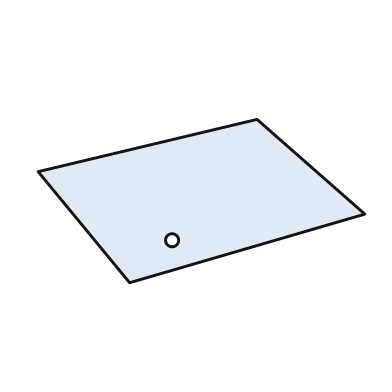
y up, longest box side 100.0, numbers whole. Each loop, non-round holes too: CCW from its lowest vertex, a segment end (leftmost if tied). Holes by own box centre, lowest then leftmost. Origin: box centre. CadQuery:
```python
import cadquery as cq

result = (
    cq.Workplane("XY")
    .moveTo(-22.0, -25.0)
    .lineTo(50.0, -4.0)
    .lineTo(17.0, 25.0)
    .lineTo(-50.0, 9.0)
    .close()
    .moveTo(-9.0, -12.0)
    .circle(2.0)
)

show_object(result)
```